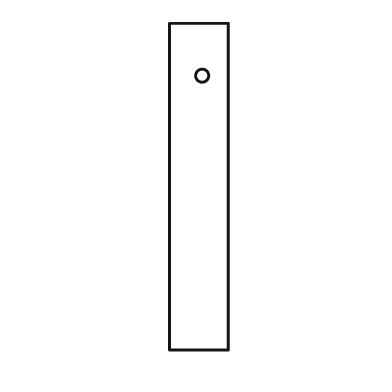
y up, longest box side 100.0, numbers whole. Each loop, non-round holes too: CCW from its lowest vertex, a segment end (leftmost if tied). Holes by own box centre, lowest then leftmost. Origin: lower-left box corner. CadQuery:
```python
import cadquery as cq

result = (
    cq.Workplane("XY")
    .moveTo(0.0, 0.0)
    .lineTo(18.0, 0.0)
    .lineTo(18.0, 100.0)
    .lineTo(0.0, 100.0)
    .close()
    .moveTo(10.0, 84.0)
    .circle(2.0)
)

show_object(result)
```